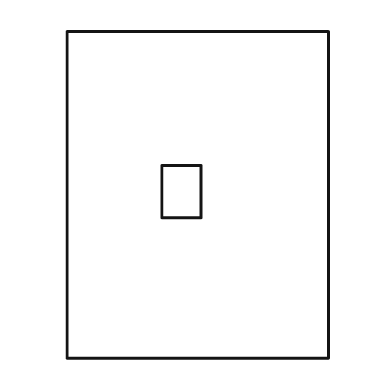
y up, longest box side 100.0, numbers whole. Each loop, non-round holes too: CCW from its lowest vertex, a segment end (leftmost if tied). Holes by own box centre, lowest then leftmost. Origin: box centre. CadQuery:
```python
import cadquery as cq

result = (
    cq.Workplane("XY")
    .moveTo(-40.0, -50.0)
    .lineTo(40.0, -50.0)
    .lineTo(40.0, 50.0)
    .lineTo(-40.0, 50.0)
    .close()
    .moveTo(-11.0, -7.0)
    .lineTo(1.0, -7.0)
    .lineTo(1.0, 9.0)
    .lineTo(-11.0, 9.0)
    .close()
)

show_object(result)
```